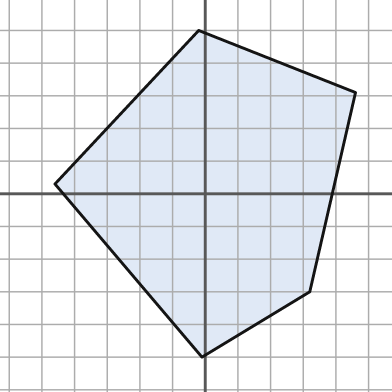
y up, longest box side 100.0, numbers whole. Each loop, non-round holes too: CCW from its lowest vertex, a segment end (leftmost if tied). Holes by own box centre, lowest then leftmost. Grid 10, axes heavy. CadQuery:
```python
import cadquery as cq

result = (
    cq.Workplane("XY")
    .moveTo(-1.0, -50.0)
    .lineTo(32.0, -30.0)
    .lineTo(46.0, 31.0)
    .lineTo(-2.0, 50.0)
    .lineTo(-46.0, 3.0)
    .close()
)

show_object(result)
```